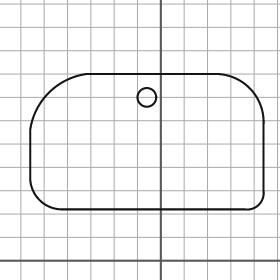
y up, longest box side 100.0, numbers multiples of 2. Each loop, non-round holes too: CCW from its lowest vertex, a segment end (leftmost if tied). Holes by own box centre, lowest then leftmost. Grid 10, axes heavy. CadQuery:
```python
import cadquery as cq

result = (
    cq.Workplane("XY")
    .moveTo(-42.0, 22.0)
    .lineTo(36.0, 22.0)
    .threePointArc((42.0, 24.0), (44.0, 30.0))
    .lineTo(44.0, 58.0)
    .threePointArc((38.0, 74.0), (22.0, 80.0))
    .lineTo(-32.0, 80.0)
    .threePointArc((-48.0, 72.0), (-56.0, 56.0))
    .lineTo(-56.0, 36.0)
    .threePointArc((-52.0, 26.0), (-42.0, 22.0))
    .close()
    .moveTo(-6.0, 70.0)
    .circle(4.0)
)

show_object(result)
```